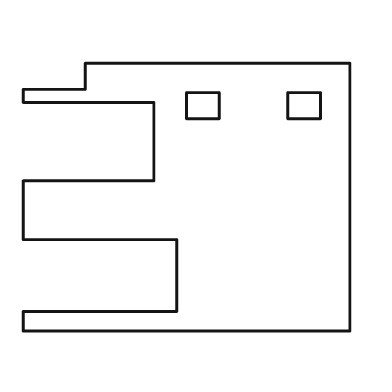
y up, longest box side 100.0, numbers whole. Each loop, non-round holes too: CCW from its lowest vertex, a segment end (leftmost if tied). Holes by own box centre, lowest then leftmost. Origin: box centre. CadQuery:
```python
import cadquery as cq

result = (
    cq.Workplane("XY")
    .moveTo(-50.0, -41.0)
    .lineTo(50.0, -41.0)
    .lineTo(50.0, 41.0)
    .lineTo(-31.0, 41.0)
    .lineTo(-31.0, 33.0)
    .lineTo(-50.0, 33.0)
    .lineTo(-50.0, 29.0)
    .lineTo(-10.0, 29.0)
    .lineTo(-10.0, 5.0)
    .lineTo(-50.0, 5.0)
    .lineTo(-50.0, -13.0)
    .lineTo(-3.0, -13.0)
    .lineTo(-3.0, -35.0)
    .lineTo(-50.0, -35.0)
    .close()
    .moveTo(0.0, 24.0)
    .lineTo(10.0, 24.0)
    .lineTo(10.0, 32.0)
    .lineTo(0.0, 32.0)
    .close()
    .moveTo(31.0, 24.0)
    .lineTo(41.0, 24.0)
    .lineTo(41.0, 32.0)
    .lineTo(31.0, 32.0)
    .close()
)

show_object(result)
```